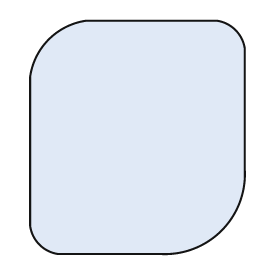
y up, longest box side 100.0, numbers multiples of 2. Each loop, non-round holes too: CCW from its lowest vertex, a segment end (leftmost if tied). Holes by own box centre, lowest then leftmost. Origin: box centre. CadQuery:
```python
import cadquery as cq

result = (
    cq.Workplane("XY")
    .moveTo(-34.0, -50.0)
    .lineTo(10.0, -50.0)
    .threePointArc((36.0, -40.0), (46.0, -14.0))
    .lineTo(46.0, 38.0)
    .threePointArc((42.0, 46.0), (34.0, 50.0))
    .lineTo(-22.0, 50.0)
    .threePointArc((-38.0, 42.0), (-46.0, 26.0))
    .lineTo(-46.0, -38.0)
    .threePointArc((-42.0, -46.0), (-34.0, -50.0))
    .close()
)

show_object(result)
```